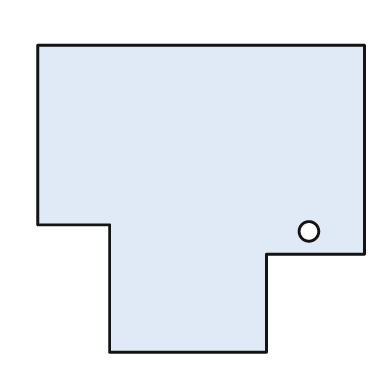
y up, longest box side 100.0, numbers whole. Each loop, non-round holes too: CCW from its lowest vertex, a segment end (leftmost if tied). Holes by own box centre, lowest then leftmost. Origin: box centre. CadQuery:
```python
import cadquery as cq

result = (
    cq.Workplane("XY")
    .moveTo(-28.0, -47.0)
    .lineTo(20.0, -47.0)
    .lineTo(20.0, -17.0)
    .lineTo(50.0, -17.0)
    .lineTo(50.0, 47.0)
    .lineTo(-50.0, 47.0)
    .lineTo(-50.0, -8.0)
    .lineTo(-28.0, -8.0)
    .close()
    .moveTo(33.0, -10.0)
    .circle(3.0)
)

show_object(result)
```